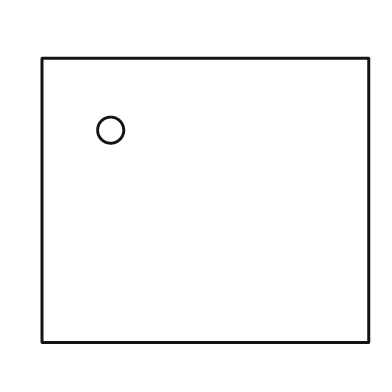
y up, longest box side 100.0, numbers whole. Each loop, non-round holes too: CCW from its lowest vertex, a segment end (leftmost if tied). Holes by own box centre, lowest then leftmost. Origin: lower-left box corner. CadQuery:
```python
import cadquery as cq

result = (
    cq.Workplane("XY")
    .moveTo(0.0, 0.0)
    .lineTo(100.0, 0.0)
    .lineTo(100.0, 87.0)
    .lineTo(0.0, 87.0)
    .close()
    .moveTo(21.0, 65.0)
    .circle(4.0)
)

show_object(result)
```